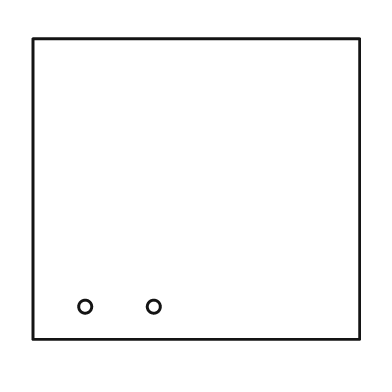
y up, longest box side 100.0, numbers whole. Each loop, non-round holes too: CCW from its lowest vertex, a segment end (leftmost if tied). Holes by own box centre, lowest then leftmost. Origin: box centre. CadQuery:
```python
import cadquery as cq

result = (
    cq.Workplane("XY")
    .moveTo(-50.0, -46.0)
    .lineTo(50.0, -46.0)
    .lineTo(50.0, 46.0)
    .lineTo(-50.0, 46.0)
    .close()
    .moveTo(-34.0, -36.0)
    .circle(2.0)
    .moveTo(-13.0, -36.0)
    .circle(2.0)
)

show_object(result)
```